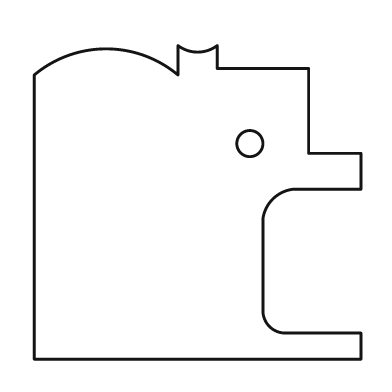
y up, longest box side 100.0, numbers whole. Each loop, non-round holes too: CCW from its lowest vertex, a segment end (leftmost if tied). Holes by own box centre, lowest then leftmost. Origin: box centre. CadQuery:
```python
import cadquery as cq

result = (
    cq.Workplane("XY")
    .moveTo(-50.0, -48.0)
    .lineTo(50.0, -48.0)
    .lineTo(50.0, -40.0)
    .lineTo(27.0, -40.0)
    .threePointArc((22.0, -38.0), (20.0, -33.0))
    .lineTo(20.0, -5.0)
    .threePointArc((23.0, 1.0), (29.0, 4.0))
    .lineTo(50.0, 4.0)
    .lineTo(50.0, 15.0)
    .lineTo(34.0, 15.0)
    .lineTo(34.0, 41.0)
    .lineTo(6.0, 41.0)
    .lineTo(6.0, 48.0)
    .threePointArc((0.0, 46.0), (-6.0, 48.0))
    .lineTo(-6.0, 39.0)
    .threePointArc((-28.0, 47.0), (-50.0, 39.0))
    .close()
    .moveTo(16.0, 18.0)
    .circle(4.0)
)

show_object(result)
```